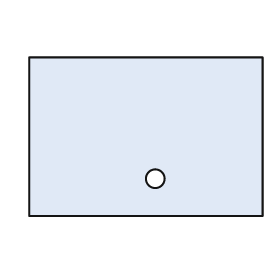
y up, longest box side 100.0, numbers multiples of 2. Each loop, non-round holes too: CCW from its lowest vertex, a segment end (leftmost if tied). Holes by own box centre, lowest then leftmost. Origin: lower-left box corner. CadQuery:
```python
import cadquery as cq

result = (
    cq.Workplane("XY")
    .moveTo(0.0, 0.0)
    .lineTo(100.0, 0.0)
    .lineTo(100.0, 68.0)
    .lineTo(0.0, 68.0)
    .close()
    .moveTo(54.0, 16.0)
    .circle(4.0)
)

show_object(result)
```